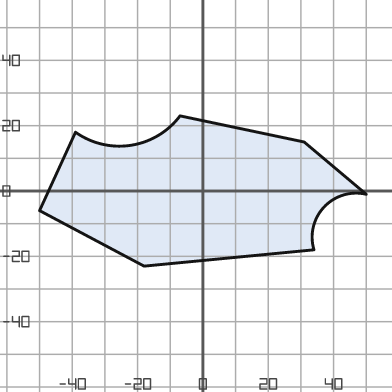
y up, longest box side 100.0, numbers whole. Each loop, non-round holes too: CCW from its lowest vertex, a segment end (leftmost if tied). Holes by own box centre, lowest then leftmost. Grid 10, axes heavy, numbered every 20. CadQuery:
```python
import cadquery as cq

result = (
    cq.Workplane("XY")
    .moveTo(-18.0, -23.0)
    .lineTo(34.0, -18.0)
    .threePointArc((37.0, -5.0), (50.0, -1.0))
    .lineTo(31.0, 15.0)
    .lineTo(-7.0, 23.0)
    .threePointArc((-22.0, 14.0), (-39.0, 18.0))
    .lineTo(-50.0, -6.0)
    .close()
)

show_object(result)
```